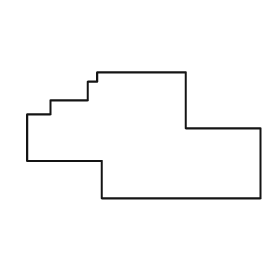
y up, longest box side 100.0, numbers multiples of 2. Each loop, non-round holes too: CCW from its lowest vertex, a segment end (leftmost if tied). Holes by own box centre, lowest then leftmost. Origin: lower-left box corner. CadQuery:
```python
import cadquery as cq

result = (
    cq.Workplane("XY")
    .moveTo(32.0, 0.0)
    .lineTo(100.0, 0.0)
    .lineTo(100.0, 30.0)
    .lineTo(68.0, 30.0)
    .lineTo(68.0, 54.0)
    .lineTo(30.0, 54.0)
    .lineTo(30.0, 50.0)
    .lineTo(26.0, 50.0)
    .lineTo(26.0, 42.0)
    .lineTo(10.0, 42.0)
    .lineTo(10.0, 36.0)
    .lineTo(0.0, 36.0)
    .lineTo(0.0, 16.0)
    .lineTo(32.0, 16.0)
    .close()
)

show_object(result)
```